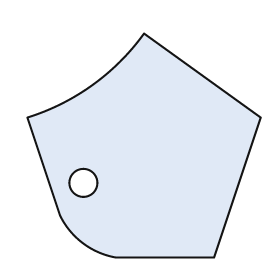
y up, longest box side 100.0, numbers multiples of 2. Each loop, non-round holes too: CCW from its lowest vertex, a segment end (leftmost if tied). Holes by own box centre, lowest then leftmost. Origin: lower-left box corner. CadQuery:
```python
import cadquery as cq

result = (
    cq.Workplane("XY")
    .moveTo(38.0, 0.0)
    .lineTo(80.0, 0.0)
    .lineTo(100.0, 60.0)
    .lineTo(50.0, 96.0)
    .threePointArc((28.0, 74.0), (0.0, 60.0))
    .lineTo(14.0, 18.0)
    .threePointArc((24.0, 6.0), (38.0, 0.0))
    .close()
    .moveTo(24.0, 32.0)
    .circle(6.0)
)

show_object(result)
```